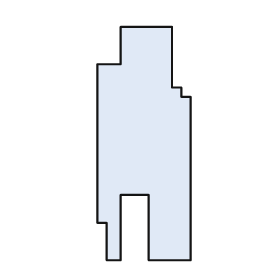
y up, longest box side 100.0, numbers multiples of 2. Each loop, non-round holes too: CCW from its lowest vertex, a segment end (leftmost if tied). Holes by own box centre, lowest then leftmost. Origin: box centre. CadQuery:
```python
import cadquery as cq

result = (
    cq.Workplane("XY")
    .moveTo(-16.0, -50.0)
    .lineTo(-10.0, -50.0)
    .lineTo(-10.0, -22.0)
    .lineTo(2.0, -22.0)
    .lineTo(2.0, -50.0)
    .lineTo(20.0, -50.0)
    .lineTo(20.0, 20.0)
    .lineTo(16.0, 20.0)
    .lineTo(16.0, 24.0)
    .lineTo(12.0, 24.0)
    .lineTo(12.0, 50.0)
    .lineTo(-10.0, 50.0)
    .lineTo(-10.0, 34.0)
    .lineTo(-20.0, 34.0)
    .lineTo(-20.0, -34.0)
    .lineTo(-16.0, -34.0)
    .close()
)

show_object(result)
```